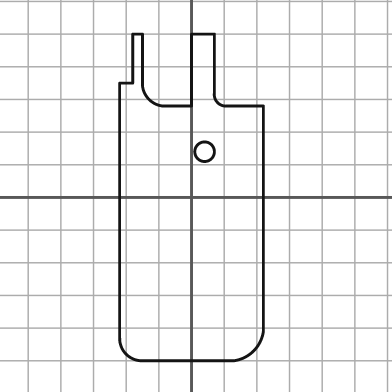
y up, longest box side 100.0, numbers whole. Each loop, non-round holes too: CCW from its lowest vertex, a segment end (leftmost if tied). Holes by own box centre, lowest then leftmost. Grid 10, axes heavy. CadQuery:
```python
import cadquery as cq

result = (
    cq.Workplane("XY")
    .moveTo(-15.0, -50.0)
    .lineTo(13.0, -50.0)
    .threePointArc((19.0, -47.0), (22.0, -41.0))
    .lineTo(22.0, 28.0)
    .lineTo(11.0, 28.0)
    .threePointArc((8.0, 29.0), (7.0, 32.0))
    .lineTo(7.0, 50.0)
    .lineTo(0.0, 50.0)
    .lineTo(0.0, 28.0)
    .lineTo(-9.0, 28.0)
    .threePointArc((-13.0, 30.0), (-15.0, 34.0))
    .lineTo(-15.0, 50.0)
    .lineTo(-18.0, 50.0)
    .lineTo(-18.0, 35.0)
    .lineTo(-22.0, 35.0)
    .lineTo(-22.0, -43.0)
    .threePointArc((-20.0, -48.0), (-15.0, -50.0))
    .close()
    .moveTo(4.0, 14.0)
    .circle(3.0)
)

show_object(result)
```